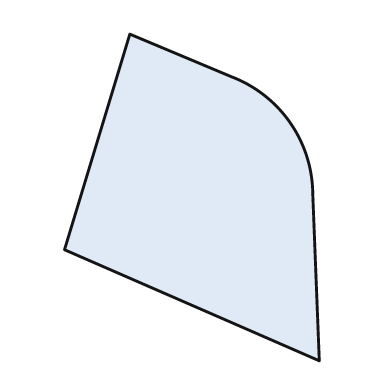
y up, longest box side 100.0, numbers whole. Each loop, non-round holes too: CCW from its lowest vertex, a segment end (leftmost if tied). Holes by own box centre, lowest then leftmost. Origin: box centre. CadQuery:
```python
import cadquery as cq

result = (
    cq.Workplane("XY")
    .moveTo(39.0, -50.0)
    .lineTo(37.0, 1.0)
    .threePointArc((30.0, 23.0), (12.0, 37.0))
    .lineTo(-19.0, 50.0)
    .lineTo(-39.0, -16.0)
    .close()
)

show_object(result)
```